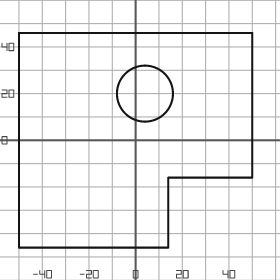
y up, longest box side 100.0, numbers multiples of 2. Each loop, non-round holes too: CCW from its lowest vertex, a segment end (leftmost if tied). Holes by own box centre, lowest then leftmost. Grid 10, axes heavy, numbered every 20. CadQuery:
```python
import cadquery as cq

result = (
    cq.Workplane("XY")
    .moveTo(-50.0, -46.0)
    .lineTo(14.0, -46.0)
    .lineTo(14.0, -16.0)
    .lineTo(50.0, -16.0)
    .lineTo(50.0, 46.0)
    .lineTo(-50.0, 46.0)
    .close()
    .moveTo(4.0, 20.0)
    .circle(12.0)
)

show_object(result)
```